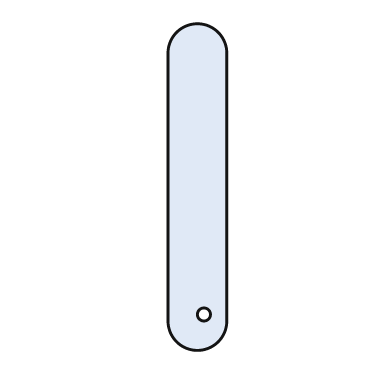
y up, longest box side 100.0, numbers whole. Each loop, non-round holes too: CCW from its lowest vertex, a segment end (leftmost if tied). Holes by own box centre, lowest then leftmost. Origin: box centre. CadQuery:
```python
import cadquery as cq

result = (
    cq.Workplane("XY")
    .moveTo(-9.0, -41.0)
    .threePointArc((0.0, -50.0), (9.0, -41.0))
    .lineTo(9.0, 41.0)
    .threePointArc((0.0, 50.0), (-9.0, 41.0))
    .close()
    .moveTo(2.0, -39.0)
    .circle(2.0)
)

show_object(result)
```